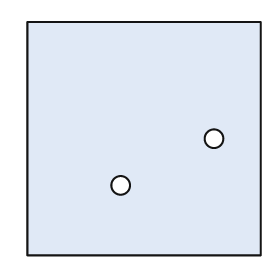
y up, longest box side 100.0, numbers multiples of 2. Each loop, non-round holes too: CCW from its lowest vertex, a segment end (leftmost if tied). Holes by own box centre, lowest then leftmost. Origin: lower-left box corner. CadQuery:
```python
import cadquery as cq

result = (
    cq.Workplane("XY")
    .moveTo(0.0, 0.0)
    .lineTo(100.0, 0.0)
    .lineTo(100.0, 100.0)
    .lineTo(0.0, 100.0)
    .close()
    .moveTo(40.0, 30.0)
    .circle(4.0)
    .moveTo(80.0, 50.0)
    .circle(4.0)
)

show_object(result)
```